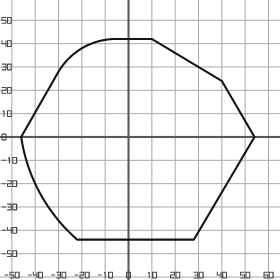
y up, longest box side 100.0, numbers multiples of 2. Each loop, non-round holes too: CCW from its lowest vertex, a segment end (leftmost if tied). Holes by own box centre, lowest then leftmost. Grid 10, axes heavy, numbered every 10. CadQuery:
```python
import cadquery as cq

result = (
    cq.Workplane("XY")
    .moveTo(-22.0, -44.0)
    .lineTo(28.0, -44.0)
    .lineTo(54.0, 0.0)
    .lineTo(40.0, 24.0)
    .lineTo(10.0, 42.0)
    .lineTo(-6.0, 42.0)
    .threePointArc((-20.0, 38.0), (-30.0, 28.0))
    .lineTo(-46.0, 0.0)
    .threePointArc((-38.0, -24.0), (-22.0, -44.0))
    .close()
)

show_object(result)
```